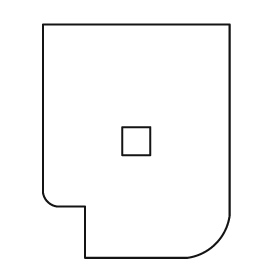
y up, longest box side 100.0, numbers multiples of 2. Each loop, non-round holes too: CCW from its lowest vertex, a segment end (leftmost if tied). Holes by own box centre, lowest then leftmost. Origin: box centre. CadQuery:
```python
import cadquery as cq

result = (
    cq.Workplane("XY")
    .moveTo(-22.0, -50.0)
    .lineTo(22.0, -50.0)
    .threePointArc((34.0, -44.0), (40.0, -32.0))
    .lineTo(40.0, 50.0)
    .lineTo(-40.0, 50.0)
    .lineTo(-40.0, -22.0)
    .threePointArc((-38.0, -26.0), (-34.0, -28.0))
    .lineTo(-22.0, -28.0)
    .close()
    .moveTo(-6.0, -6.0)
    .lineTo(6.0, -6.0)
    .lineTo(6.0, 6.0)
    .lineTo(-6.0, 6.0)
    .close()
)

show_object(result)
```